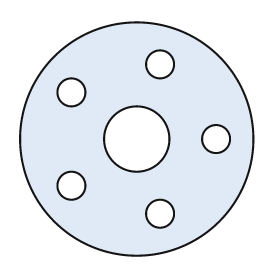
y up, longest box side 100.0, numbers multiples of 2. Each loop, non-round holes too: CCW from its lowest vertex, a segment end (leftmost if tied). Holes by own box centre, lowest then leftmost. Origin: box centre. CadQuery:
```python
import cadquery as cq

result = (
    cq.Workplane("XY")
    .moveTo(0.0, 0.0)
    .circle(50.0)
    .moveTo(10.0, -32.0)
    .circle(6.0)
    .moveTo(-28.0, -20.0)
    .circle(6.0)
    .moveTo(0.0, 0.0)
    .circle(14.0)
    .moveTo(34.0, 0.0)
    .circle(6.0)
    .moveTo(-28.0, 20.0)
    .circle(6.0)
    .moveTo(10.0, 32.0)
    .circle(6.0)
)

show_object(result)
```